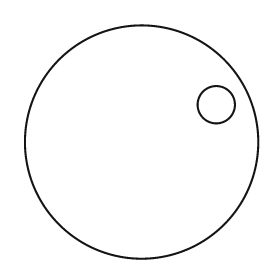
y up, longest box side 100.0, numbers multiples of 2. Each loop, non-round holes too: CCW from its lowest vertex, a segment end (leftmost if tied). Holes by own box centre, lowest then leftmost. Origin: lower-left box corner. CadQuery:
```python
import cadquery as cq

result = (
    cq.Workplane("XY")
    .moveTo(50.0, 50.0)
    .circle(50.0)
    .moveTo(82.0, 66.0)
    .circle(8.0)
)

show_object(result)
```